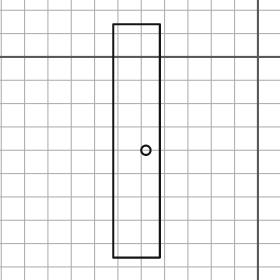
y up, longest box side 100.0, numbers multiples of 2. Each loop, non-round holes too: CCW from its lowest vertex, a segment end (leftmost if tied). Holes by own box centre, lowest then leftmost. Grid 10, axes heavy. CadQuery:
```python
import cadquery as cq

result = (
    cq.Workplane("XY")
    .moveTo(-62.0, -86.0)
    .lineTo(-42.0, -86.0)
    .lineTo(-42.0, 14.0)
    .lineTo(-62.0, 14.0)
    .close()
    .moveTo(-48.0, -40.0)
    .circle(2.0)
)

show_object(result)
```